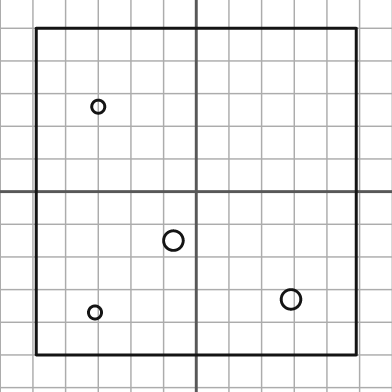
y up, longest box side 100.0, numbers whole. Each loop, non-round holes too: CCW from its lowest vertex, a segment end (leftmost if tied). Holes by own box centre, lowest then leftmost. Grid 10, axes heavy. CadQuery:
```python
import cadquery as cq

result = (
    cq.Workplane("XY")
    .moveTo(-49.0, -50.0)
    .lineTo(49.0, -50.0)
    .lineTo(49.0, 50.0)
    .lineTo(-49.0, 50.0)
    .close()
    .moveTo(-31.0, -37.0)
    .circle(2.0)
    .moveTo(29.0, -33.0)
    .circle(3.0)
    .moveTo(-7.0, -15.0)
    .circle(3.0)
    .moveTo(-30.0, 26.0)
    .circle(2.0)
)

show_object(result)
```